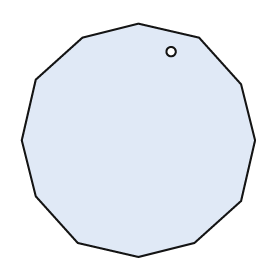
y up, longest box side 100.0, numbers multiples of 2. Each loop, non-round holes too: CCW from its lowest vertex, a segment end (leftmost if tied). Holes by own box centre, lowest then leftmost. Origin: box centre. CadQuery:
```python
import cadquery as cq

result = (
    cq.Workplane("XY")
    .moveTo(0.0, -50.0)
    .lineTo(24.0, -44.0)
    .lineTo(44.0, -26.0)
    .lineTo(50.0, 0.0)
    .lineTo(44.0, 24.0)
    .lineTo(26.0, 44.0)
    .lineTo(0.0, 50.0)
    .lineTo(-24.0, 44.0)
    .lineTo(-44.0, 26.0)
    .lineTo(-50.0, 0.0)
    .lineTo(-44.0, -24.0)
    .lineTo(-26.0, -44.0)
    .close()
    .moveTo(14.0, 38.0)
    .circle(2.0)
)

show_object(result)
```